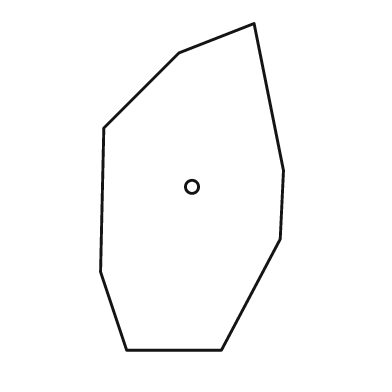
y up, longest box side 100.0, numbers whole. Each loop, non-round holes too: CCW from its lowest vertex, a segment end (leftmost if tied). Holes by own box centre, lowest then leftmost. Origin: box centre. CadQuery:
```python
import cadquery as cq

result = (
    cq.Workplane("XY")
    .moveTo(-20.0, -50.0)
    .lineTo(9.0, -50.0)
    .lineTo(27.0, -16.0)
    .lineTo(28.0, 5.0)
    .lineTo(19.0, 50.0)
    .lineTo(-4.0, 41.0)
    .lineTo(-27.0, 18.0)
    .lineTo(-28.0, -26.0)
    .close()
    .moveTo(0.0, 0.0)
    .circle(2.0)
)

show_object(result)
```